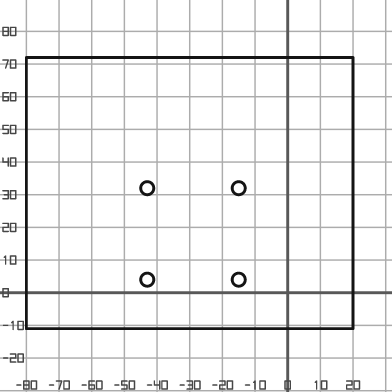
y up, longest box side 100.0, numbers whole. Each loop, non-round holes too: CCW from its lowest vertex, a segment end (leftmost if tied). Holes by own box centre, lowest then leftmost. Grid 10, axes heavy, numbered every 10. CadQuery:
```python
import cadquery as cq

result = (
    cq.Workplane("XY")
    .moveTo(-80.0, -11.0)
    .lineTo(20.0, -11.0)
    .lineTo(20.0, 72.0)
    .lineTo(-80.0, 72.0)
    .close()
    .moveTo(-43.0, 4.0)
    .circle(2.0)
    .moveTo(-15.0, 4.0)
    .circle(2.0)
    .moveTo(-43.0, 32.0)
    .circle(2.0)
    .moveTo(-15.0, 32.0)
    .circle(2.0)
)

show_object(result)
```